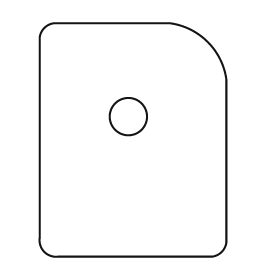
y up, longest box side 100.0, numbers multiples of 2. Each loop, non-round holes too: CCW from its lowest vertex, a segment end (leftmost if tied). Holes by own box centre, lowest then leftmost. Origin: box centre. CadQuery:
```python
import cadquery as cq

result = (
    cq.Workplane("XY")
    .moveTo(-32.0, -50.0)
    .lineTo(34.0, -50.0)
    .threePointArc((38.0, -48.0), (40.0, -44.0))
    .lineTo(40.0, 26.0)
    .threePointArc((32.0, 42.0), (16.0, 50.0))
    .lineTo(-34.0, 50.0)
    .threePointArc((-38.0, 48.0), (-40.0, 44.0))
    .lineTo(-40.0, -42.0)
    .threePointArc((-38.0, -48.0), (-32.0, -50.0))
    .close()
    .moveTo(-2.0, 10.0)
    .circle(8.0)
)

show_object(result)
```